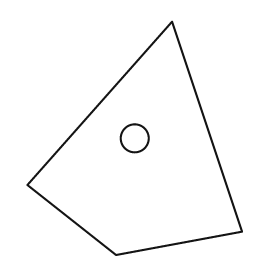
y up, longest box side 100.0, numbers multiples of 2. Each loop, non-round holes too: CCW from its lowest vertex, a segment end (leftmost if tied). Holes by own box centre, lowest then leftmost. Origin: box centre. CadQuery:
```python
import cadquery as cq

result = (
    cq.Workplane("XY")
    .moveTo(-8.0, -50.0)
    .lineTo(46.0, -40.0)
    .lineTo(16.0, 50.0)
    .lineTo(-46.0, -20.0)
    .close()
    .moveTo(0.0, 0.0)
    .circle(6.0)
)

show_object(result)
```